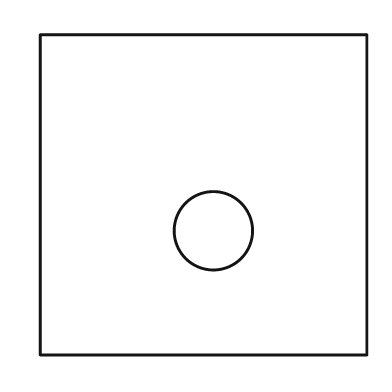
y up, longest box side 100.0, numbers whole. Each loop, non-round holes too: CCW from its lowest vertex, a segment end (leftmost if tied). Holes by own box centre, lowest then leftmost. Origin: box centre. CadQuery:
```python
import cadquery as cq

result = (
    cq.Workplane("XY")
    .moveTo(-50.0, -49.0)
    .lineTo(50.0, -49.0)
    .lineTo(50.0, 49.0)
    .lineTo(-50.0, 49.0)
    .close()
    .moveTo(3.0, -11.0)
    .circle(12.0)
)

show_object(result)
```